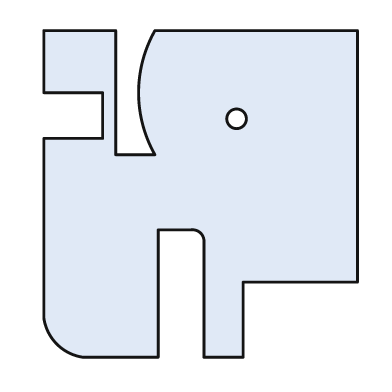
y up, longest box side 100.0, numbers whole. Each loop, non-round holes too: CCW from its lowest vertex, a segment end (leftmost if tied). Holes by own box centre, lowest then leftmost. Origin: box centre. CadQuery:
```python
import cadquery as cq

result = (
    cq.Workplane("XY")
    .moveTo(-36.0, -50.0)
    .lineTo(-13.0, -50.0)
    .lineTo(-13.0, -11.0)
    .lineTo(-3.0, -11.0)
    .threePointArc((0.0, -12.0), (1.0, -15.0))
    .lineTo(1.0, -50.0)
    .lineTo(13.0, -50.0)
    .lineTo(13.0, -27.0)
    .lineTo(48.0, -27.0)
    .lineTo(48.0, 50.0)
    .lineTo(-14.0, 50.0)
    .threePointArc((-19.0, 31.0), (-14.0, 12.0))
    .lineTo(-26.0, 12.0)
    .lineTo(-26.0, 50.0)
    .lineTo(-48.0, 50.0)
    .lineTo(-48.0, 31.0)
    .lineTo(-30.0, 31.0)
    .lineTo(-30.0, 17.0)
    .lineTo(-48.0, 17.0)
    .lineTo(-48.0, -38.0)
    .threePointArc((-44.0, -46.0), (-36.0, -50.0))
    .close()
    .moveTo(11.0, 23.0)
    .circle(3.0)
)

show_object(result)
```